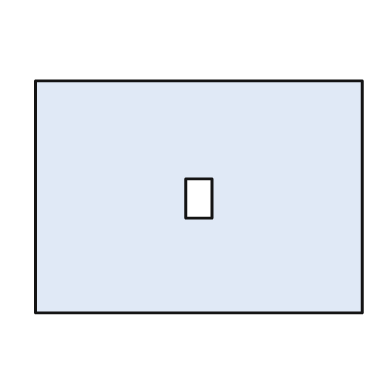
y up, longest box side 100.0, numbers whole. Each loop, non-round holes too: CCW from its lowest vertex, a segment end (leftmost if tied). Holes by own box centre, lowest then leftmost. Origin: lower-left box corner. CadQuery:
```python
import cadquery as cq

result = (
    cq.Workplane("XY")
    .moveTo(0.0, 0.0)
    .lineTo(100.0, 0.0)
    .lineTo(100.0, 71.0)
    .lineTo(0.0, 71.0)
    .close()
    .moveTo(46.0, 29.0)
    .lineTo(54.0, 29.0)
    .lineTo(54.0, 41.0)
    .lineTo(46.0, 41.0)
    .close()
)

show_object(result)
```